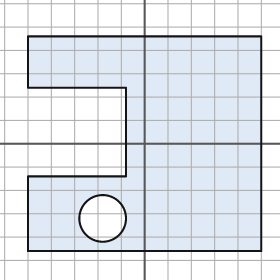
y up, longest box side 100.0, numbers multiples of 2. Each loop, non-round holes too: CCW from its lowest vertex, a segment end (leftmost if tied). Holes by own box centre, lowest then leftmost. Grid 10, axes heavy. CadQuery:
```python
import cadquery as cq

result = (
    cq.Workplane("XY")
    .moveTo(-50.0, -46.0)
    .lineTo(50.0, -46.0)
    .lineTo(50.0, 46.0)
    .lineTo(-50.0, 46.0)
    .lineTo(-50.0, 24.0)
    .lineTo(-8.0, 24.0)
    .lineTo(-8.0, -14.0)
    .lineTo(-50.0, -14.0)
    .close()
    .moveTo(-18.0, -32.0)
    .circle(10.0)
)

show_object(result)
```